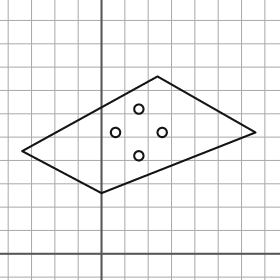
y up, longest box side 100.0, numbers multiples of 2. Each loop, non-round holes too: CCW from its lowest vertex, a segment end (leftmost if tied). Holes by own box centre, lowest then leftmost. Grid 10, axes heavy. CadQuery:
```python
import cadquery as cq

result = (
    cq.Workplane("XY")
    .moveTo(0.0, 26.0)
    .lineTo(66.0, 52.0)
    .lineTo(24.0, 76.0)
    .lineTo(-34.0, 44.0)
    .close()
    .moveTo(16.0, 42.0)
    .circle(2.0)
    .moveTo(6.0, 52.0)
    .circle(2.0)
    .moveTo(26.0, 52.0)
    .circle(2.0)
    .moveTo(16.0, 62.0)
    .circle(2.0)
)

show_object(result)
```